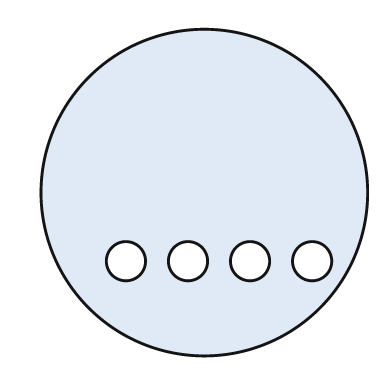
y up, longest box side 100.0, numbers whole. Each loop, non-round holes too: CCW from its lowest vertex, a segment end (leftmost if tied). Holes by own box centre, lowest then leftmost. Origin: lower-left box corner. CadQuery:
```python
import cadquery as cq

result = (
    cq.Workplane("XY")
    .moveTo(50.0, 50.0)
    .circle(50.0)
    .moveTo(26.0, 29.0)
    .circle(6.0)
    .moveTo(45.0, 29.0)
    .circle(6.0)
    .moveTo(64.0, 29.0)
    .circle(6.0)
    .moveTo(83.0, 29.0)
    .circle(6.0)
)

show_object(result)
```